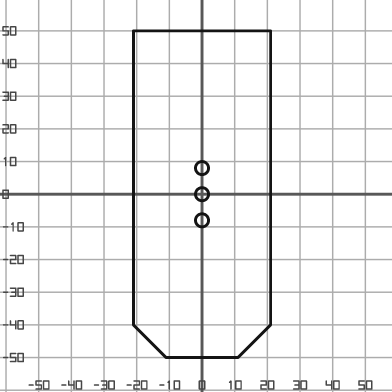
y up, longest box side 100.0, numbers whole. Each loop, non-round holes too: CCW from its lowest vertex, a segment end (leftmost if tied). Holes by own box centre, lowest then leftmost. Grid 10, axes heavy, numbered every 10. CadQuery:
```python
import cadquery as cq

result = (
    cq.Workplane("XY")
    .moveTo(-11.0, -50.0)
    .lineTo(11.0, -50.0)
    .lineTo(21.0, -40.0)
    .lineTo(21.0, 50.0)
    .lineTo(-21.0, 50.0)
    .lineTo(-21.0, -40.0)
    .close()
    .moveTo(0.0, -8.0)
    .circle(2.0)
    .moveTo(0.0, 0.0)
    .circle(2.0)
    .moveTo(0.0, 8.0)
    .circle(2.0)
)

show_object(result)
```